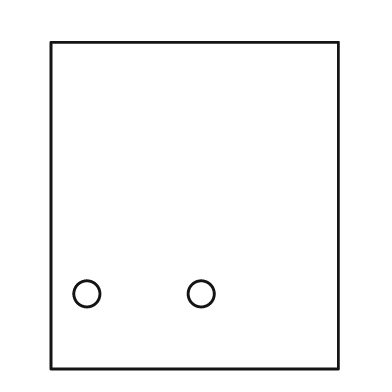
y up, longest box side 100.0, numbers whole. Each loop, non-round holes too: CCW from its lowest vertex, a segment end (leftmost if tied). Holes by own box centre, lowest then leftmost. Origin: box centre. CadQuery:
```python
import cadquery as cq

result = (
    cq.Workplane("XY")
    .moveTo(-44.0, -50.0)
    .lineTo(44.0, -50.0)
    .lineTo(44.0, 50.0)
    .lineTo(-44.0, 50.0)
    .close()
    .moveTo(-33.0, -27.0)
    .circle(4.0)
    .moveTo(2.0, -27.0)
    .circle(4.0)
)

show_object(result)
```